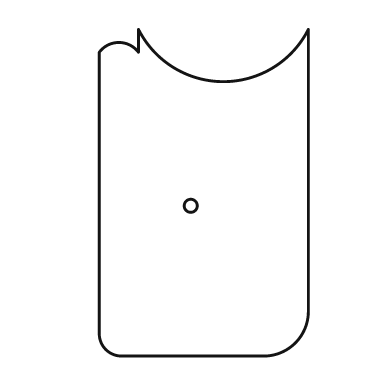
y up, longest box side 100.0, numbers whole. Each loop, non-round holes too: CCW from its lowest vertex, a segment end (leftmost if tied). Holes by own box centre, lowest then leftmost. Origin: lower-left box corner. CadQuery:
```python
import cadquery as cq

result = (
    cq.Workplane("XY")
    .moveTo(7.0, 0.0)
    .lineTo(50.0, 0.0)
    .threePointArc((60.0, 4.0), (64.0, 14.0))
    .lineTo(64.0, 100.0)
    .threePointArc((38.0, 84.0), (12.0, 100.0))
    .lineTo(12.0, 93.0)
    .threePointArc((6.0, 96.0), (0.0, 93.0))
    .lineTo(0.0, 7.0)
    .threePointArc((2.0, 2.0), (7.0, 0.0))
    .close()
    .moveTo(28.0, 46.0)
    .circle(2.0)
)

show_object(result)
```